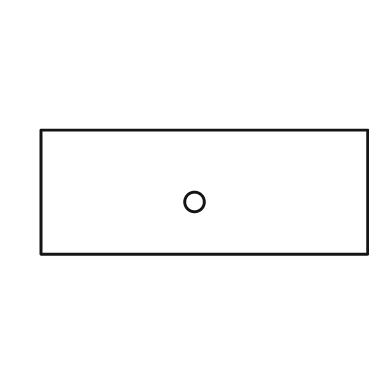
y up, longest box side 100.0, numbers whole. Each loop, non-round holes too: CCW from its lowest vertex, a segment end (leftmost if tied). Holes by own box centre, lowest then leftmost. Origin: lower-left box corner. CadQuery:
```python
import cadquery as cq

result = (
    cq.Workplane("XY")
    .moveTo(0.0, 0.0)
    .lineTo(100.0, 0.0)
    .lineTo(100.0, 38.0)
    .lineTo(0.0, 38.0)
    .close()
    .moveTo(47.0, 16.0)
    .circle(3.0)
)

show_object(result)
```